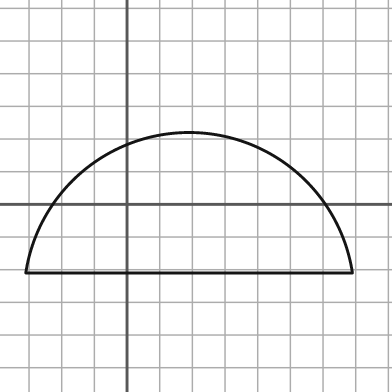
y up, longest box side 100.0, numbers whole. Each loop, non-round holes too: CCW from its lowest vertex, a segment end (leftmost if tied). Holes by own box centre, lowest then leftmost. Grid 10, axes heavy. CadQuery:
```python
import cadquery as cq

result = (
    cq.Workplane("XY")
    .moveTo(-31.0, -21.0)
    .lineTo(69.0, -21.0)
    .threePointArc((19.0, 22.0), (-31.0, -21.0))
    .close()
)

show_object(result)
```